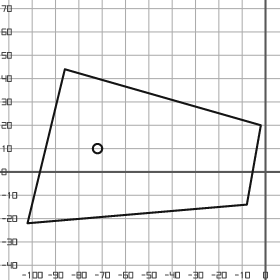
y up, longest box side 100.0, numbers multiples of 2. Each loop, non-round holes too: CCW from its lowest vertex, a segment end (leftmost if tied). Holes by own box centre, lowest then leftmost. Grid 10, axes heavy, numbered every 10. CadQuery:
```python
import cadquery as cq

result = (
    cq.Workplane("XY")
    .moveTo(-102.0, -22.0)
    .lineTo(-8.0, -14.0)
    .lineTo(-2.0, 20.0)
    .lineTo(-86.0, 44.0)
    .close()
    .moveTo(-72.0, 10.0)
    .circle(2.0)
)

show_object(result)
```